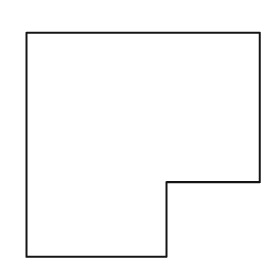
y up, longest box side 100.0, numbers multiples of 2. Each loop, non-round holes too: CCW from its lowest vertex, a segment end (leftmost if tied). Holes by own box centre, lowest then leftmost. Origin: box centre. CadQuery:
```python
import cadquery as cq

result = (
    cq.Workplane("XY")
    .moveTo(-50.0, -48.0)
    .lineTo(10.0, -48.0)
    .lineTo(10.0, -16.0)
    .lineTo(50.0, -16.0)
    .lineTo(50.0, 48.0)
    .lineTo(-50.0, 48.0)
    .close()
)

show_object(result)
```